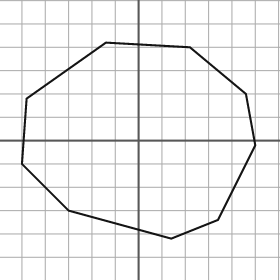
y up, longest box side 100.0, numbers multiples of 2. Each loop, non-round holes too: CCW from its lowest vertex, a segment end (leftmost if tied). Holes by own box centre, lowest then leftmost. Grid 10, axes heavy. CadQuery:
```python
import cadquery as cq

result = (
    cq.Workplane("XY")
    .moveTo(14.0, -42.0)
    .lineTo(34.0, -34.0)
    .lineTo(50.0, -2.0)
    .lineTo(46.0, 20.0)
    .lineTo(22.0, 40.0)
    .lineTo(-14.0, 42.0)
    .lineTo(-48.0, 18.0)
    .lineTo(-50.0, -10.0)
    .lineTo(-30.0, -30.0)
    .close()
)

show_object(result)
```